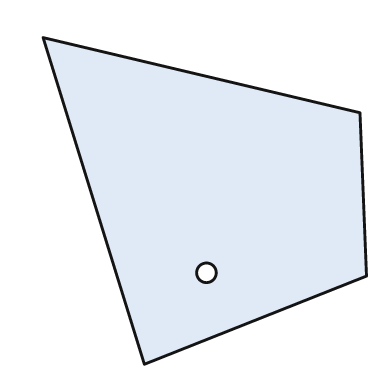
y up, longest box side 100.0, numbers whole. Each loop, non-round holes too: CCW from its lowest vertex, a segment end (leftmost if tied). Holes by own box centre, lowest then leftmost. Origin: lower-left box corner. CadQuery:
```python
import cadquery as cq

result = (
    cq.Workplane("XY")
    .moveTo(31.0, 0.0)
    .lineTo(99.0, 27.0)
    .lineTo(97.0, 77.0)
    .lineTo(0.0, 100.0)
    .close()
    .moveTo(50.0, 28.0)
    .circle(3.0)
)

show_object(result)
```